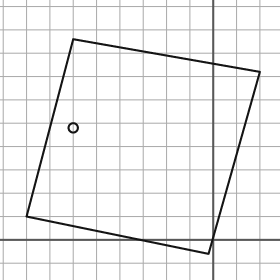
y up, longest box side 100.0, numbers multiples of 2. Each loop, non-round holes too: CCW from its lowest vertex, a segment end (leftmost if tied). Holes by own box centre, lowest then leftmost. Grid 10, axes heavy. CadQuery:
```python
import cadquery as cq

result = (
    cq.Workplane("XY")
    .moveTo(-2.0, -6.0)
    .lineTo(20.0, 72.0)
    .lineTo(-60.0, 86.0)
    .lineTo(-80.0, 10.0)
    .close()
    .moveTo(-60.0, 48.0)
    .circle(2.0)
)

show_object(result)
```